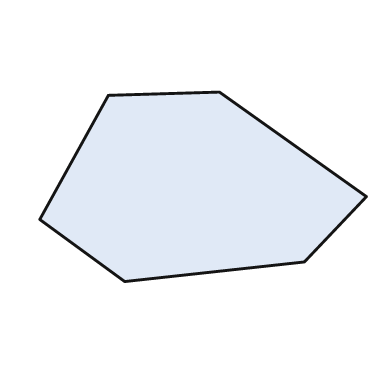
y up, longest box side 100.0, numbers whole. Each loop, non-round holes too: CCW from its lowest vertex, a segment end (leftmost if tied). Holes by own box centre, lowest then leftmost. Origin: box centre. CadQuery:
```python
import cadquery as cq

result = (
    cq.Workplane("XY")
    .moveTo(-24.0, -29.0)
    .lineTo(31.0, -23.0)
    .lineTo(50.0, -3.0)
    .lineTo(5.0, 29.0)
    .lineTo(-29.0, 28.0)
    .lineTo(-50.0, -10.0)
    .close()
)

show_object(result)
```